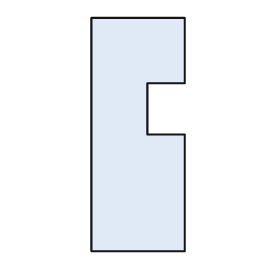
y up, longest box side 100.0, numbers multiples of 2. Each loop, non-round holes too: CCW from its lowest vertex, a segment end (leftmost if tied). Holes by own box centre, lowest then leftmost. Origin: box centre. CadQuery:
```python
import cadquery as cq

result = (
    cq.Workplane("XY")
    .moveTo(-20.0, -50.0)
    .lineTo(20.0, -50.0)
    .lineTo(20.0, 0.0)
    .lineTo(4.0, 0.0)
    .lineTo(4.0, 22.0)
    .lineTo(20.0, 22.0)
    .lineTo(20.0, 50.0)
    .lineTo(-20.0, 50.0)
    .close()
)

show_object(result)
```